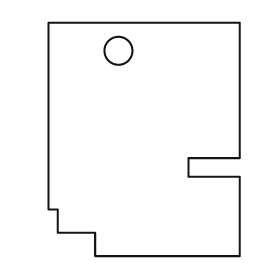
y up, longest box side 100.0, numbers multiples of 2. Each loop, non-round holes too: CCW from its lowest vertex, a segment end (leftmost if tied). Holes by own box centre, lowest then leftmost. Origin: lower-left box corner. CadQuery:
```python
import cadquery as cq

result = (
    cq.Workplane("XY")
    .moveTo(20.0, 0.0)
    .lineTo(82.0, 0.0)
    .lineTo(82.0, 34.0)
    .lineTo(60.0, 34.0)
    .lineTo(60.0, 42.0)
    .lineTo(82.0, 42.0)
    .lineTo(82.0, 100.0)
    .lineTo(0.0, 100.0)
    .lineTo(0.0, 20.0)
    .lineTo(4.0, 20.0)
    .lineTo(4.0, 10.0)
    .lineTo(20.0, 10.0)
    .close()
    .moveTo(30.0, 88.0)
    .circle(6.0)
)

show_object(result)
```